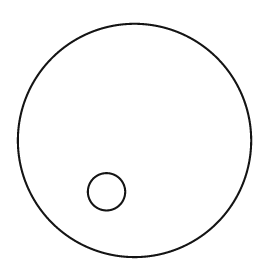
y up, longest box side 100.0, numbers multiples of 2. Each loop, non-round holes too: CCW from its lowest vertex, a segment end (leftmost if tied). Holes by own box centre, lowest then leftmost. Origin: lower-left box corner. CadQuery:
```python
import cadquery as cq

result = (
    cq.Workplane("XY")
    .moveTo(50.0, 50.0)
    .circle(50.0)
    .moveTo(38.0, 28.0)
    .circle(8.0)
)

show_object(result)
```